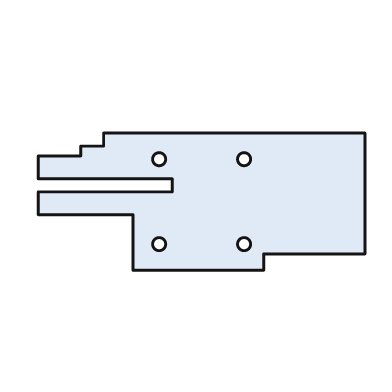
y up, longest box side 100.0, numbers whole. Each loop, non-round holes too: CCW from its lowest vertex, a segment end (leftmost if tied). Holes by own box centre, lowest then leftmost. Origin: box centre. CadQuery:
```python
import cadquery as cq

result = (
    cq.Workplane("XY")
    .moveTo(-21.0, -21.0)
    .lineTo(19.0, -21.0)
    .lineTo(19.0, -16.0)
    .lineTo(50.0, -16.0)
    .lineTo(50.0, 21.0)
    .lineTo(-30.0, 21.0)
    .lineTo(-30.0, 17.0)
    .lineTo(-37.0, 17.0)
    .lineTo(-37.0, 14.0)
    .lineTo(-50.0, 14.0)
    .lineTo(-50.0, 7.0)
    .lineTo(-9.0, 7.0)
    .lineTo(-9.0, 3.0)
    .lineTo(-50.0, 3.0)
    .lineTo(-50.0, -4.0)
    .lineTo(-21.0, -4.0)
    .close()
    .moveTo(-13.0, -13.0)
    .circle(2.0)
    .moveTo(13.0, -13.0)
    .circle(2.0)
    .moveTo(-13.0, 13.0)
    .circle(2.0)
    .moveTo(13.0, 13.0)
    .circle(2.0)
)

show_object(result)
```